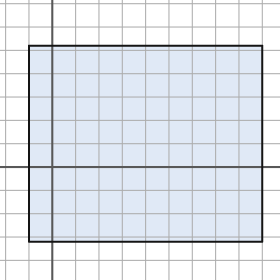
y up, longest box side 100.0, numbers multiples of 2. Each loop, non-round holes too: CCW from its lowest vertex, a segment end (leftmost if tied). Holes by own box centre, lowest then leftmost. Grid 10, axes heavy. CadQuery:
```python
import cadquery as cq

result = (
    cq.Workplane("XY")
    .moveTo(-10.0, -32.0)
    .lineTo(90.0, -32.0)
    .lineTo(90.0, 52.0)
    .lineTo(-10.0, 52.0)
    .close()
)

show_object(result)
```